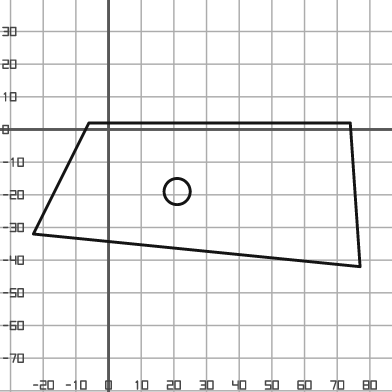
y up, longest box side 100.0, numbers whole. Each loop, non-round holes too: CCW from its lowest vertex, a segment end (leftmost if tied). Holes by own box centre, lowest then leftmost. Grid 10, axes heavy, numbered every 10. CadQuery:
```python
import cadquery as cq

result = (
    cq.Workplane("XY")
    .moveTo(77.0, -42.0)
    .lineTo(74.0, 2.0)
    .lineTo(-6.0, 2.0)
    .lineTo(-23.0, -32.0)
    .close()
    .moveTo(21.0, -19.0)
    .circle(4.0)
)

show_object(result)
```